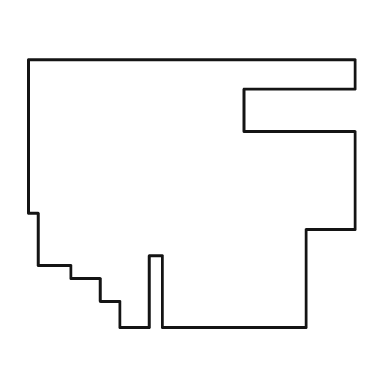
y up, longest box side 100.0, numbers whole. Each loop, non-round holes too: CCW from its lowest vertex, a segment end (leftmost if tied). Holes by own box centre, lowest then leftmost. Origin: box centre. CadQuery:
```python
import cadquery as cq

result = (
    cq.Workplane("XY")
    .moveTo(-22.0, -41.0)
    .lineTo(-13.0, -41.0)
    .lineTo(-13.0, -19.0)
    .lineTo(-9.0, -19.0)
    .lineTo(-9.0, -41.0)
    .lineTo(35.0, -41.0)
    .lineTo(35.0, -11.0)
    .lineTo(50.0, -11.0)
    .lineTo(50.0, 19.0)
    .lineTo(16.0, 19.0)
    .lineTo(16.0, 32.0)
    .lineTo(50.0, 32.0)
    .lineTo(50.0, 41.0)
    .lineTo(-50.0, 41.0)
    .lineTo(-50.0, -6.0)
    .lineTo(-47.0, -6.0)
    .lineTo(-47.0, -22.0)
    .lineTo(-37.0, -22.0)
    .lineTo(-37.0, -26.0)
    .lineTo(-28.0, -26.0)
    .lineTo(-28.0, -33.0)
    .lineTo(-22.0, -33.0)
    .close()
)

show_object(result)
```